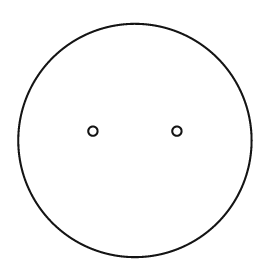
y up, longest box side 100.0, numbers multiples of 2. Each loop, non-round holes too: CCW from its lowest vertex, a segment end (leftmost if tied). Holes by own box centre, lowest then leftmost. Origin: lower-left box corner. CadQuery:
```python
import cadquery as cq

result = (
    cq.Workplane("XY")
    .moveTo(50.0, 50.0)
    .circle(50.0)
    .moveTo(32.0, 54.0)
    .circle(2.0)
    .moveTo(68.0, 54.0)
    .circle(2.0)
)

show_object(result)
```